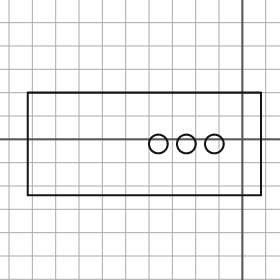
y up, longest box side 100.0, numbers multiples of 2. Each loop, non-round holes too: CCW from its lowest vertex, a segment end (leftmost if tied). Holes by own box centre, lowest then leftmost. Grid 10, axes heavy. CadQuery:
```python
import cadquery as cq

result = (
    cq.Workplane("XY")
    .moveTo(-92.0, -24.0)
    .lineTo(8.0, -24.0)
    .lineTo(8.0, 20.0)
    .lineTo(-92.0, 20.0)
    .close()
    .moveTo(-36.0, -2.0)
    .circle(4.0)
    .moveTo(-24.0, -2.0)
    .circle(4.0)
    .moveTo(-12.0, -2.0)
    .circle(4.0)
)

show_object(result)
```